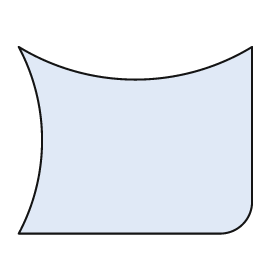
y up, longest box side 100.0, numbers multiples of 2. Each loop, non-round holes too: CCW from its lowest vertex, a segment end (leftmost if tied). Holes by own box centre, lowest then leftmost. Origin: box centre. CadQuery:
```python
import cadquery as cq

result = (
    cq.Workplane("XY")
    .moveTo(-50.0, -40.0)
    .lineTo(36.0, -40.0)
    .threePointArc((46.0, -36.0), (50.0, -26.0))
    .lineTo(50.0, 40.0)
    .threePointArc((0.0, 26.0), (-50.0, 40.0))
    .threePointArc((-40.0, 0.0), (-50.0, -40.0))
    .close()
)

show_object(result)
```